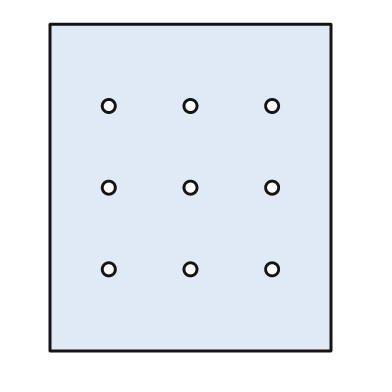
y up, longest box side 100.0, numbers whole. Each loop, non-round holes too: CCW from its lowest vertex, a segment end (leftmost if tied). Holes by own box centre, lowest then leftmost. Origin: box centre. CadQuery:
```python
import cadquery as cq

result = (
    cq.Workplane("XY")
    .moveTo(-43.0, -50.0)
    .lineTo(43.0, -50.0)
    .lineTo(43.0, 50.0)
    .lineTo(-43.0, 50.0)
    .close()
    .moveTo(-25.0, -25.0)
    .circle(2.0)
    .moveTo(0.0, -25.0)
    .circle(2.0)
    .moveTo(25.0, -25.0)
    .circle(2.0)
    .moveTo(-25.0, 0.0)
    .circle(2.0)
    .moveTo(0.0, 0.0)
    .circle(2.0)
    .moveTo(25.0, 0.0)
    .circle(2.0)
    .moveTo(-25.0, 25.0)
    .circle(2.0)
    .moveTo(0.0, 25.0)
    .circle(2.0)
    .moveTo(25.0, 25.0)
    .circle(2.0)
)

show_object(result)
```